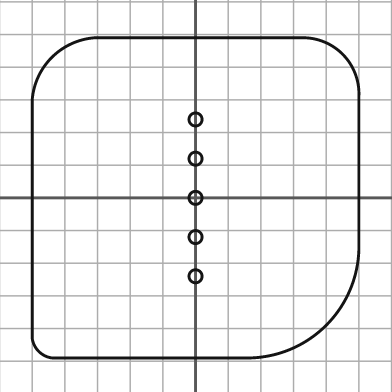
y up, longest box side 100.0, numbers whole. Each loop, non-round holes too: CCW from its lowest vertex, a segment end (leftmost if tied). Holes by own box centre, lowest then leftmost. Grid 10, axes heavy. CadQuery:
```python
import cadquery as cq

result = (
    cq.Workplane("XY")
    .moveTo(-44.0, -49.0)
    .lineTo(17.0, -49.0)
    .threePointArc((40.0, -39.0), (50.0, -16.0))
    .lineTo(50.0, 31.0)
    .threePointArc((45.0, 44.0), (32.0, 49.0))
    .lineTo(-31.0, 49.0)
    .threePointArc((-44.0, 43.0), (-50.0, 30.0))
    .lineTo(-50.0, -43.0)
    .threePointArc((-48.0, -47.0), (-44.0, -49.0))
    .close()
    .moveTo(0.0, -24.0)
    .circle(2.0)
    .moveTo(0.0, -12.0)
    .circle(2.0)
    .moveTo(0.0, 0.0)
    .circle(2.0)
    .moveTo(0.0, 12.0)
    .circle(2.0)
    .moveTo(0.0, 24.0)
    .circle(2.0)
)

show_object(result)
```